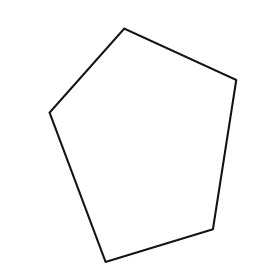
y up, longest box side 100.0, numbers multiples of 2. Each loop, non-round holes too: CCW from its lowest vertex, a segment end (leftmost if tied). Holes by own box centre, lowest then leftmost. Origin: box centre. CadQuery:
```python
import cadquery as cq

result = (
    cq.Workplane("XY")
    .moveTo(-16.0, -50.0)
    .lineTo(30.0, -36.0)
    .lineTo(40.0, 28.0)
    .lineTo(-8.0, 50.0)
    .lineTo(-40.0, 14.0)
    .close()
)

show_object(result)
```